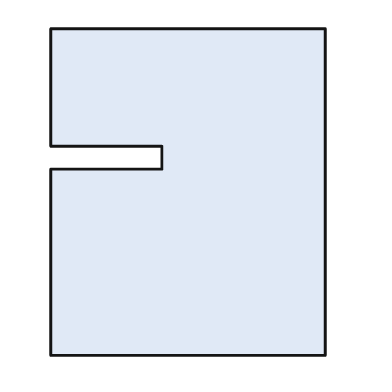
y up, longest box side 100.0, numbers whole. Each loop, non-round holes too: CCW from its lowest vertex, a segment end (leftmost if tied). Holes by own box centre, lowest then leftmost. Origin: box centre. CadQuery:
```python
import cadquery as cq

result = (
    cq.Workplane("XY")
    .moveTo(-42.0, -50.0)
    .lineTo(42.0, -50.0)
    .lineTo(42.0, 50.0)
    .lineTo(-42.0, 50.0)
    .lineTo(-42.0, 14.0)
    .lineTo(-8.0, 14.0)
    .lineTo(-8.0, 7.0)
    .lineTo(-42.0, 7.0)
    .close()
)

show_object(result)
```